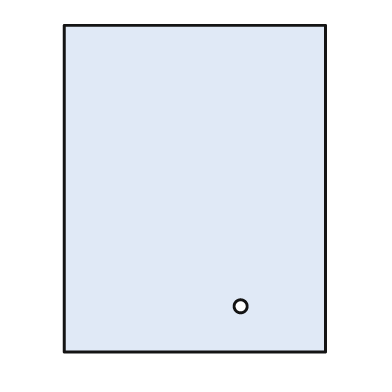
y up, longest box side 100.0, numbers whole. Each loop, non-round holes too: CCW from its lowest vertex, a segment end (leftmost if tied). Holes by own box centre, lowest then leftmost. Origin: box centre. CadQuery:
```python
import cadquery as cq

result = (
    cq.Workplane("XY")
    .moveTo(-40.0, -50.0)
    .lineTo(40.0, -50.0)
    .lineTo(40.0, 50.0)
    .lineTo(-40.0, 50.0)
    .close()
    .moveTo(14.0, -36.0)
    .circle(2.0)
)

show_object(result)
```